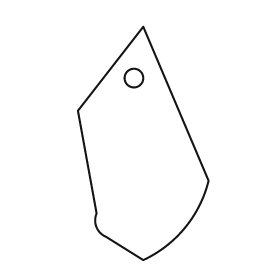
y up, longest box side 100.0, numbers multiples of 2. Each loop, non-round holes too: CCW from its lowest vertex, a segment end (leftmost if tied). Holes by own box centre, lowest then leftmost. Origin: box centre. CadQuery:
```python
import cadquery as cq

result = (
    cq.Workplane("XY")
    .moveTo(0.0, -50.0)
    .threePointArc((18.0, -36.0), (28.0, -16.0))
    .lineTo(0.0, 50.0)
    .lineTo(-28.0, 14.0)
    .lineTo(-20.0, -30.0)
    .threePointArc((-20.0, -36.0), (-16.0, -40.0))
    .close()
    .moveTo(-4.0, 28.0)
    .circle(4.0)
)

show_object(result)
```